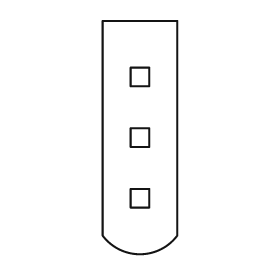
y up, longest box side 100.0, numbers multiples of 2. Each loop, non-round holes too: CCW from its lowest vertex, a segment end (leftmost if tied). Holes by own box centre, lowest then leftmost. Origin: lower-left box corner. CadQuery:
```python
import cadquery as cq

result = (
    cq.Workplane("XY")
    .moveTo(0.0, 8.0)
    .threePointArc((16.0, 0.0), (32.0, 8.0))
    .lineTo(32.0, 100.0)
    .lineTo(0.0, 100.0)
    .close()
    .moveTo(12.0, 20.0)
    .lineTo(20.0, 20.0)
    .lineTo(20.0, 28.0)
    .lineTo(12.0, 28.0)
    .close()
    .moveTo(12.0, 46.0)
    .lineTo(20.0, 46.0)
    .lineTo(20.0, 54.0)
    .lineTo(12.0, 54.0)
    .close()
    .moveTo(12.0, 72.0)
    .lineTo(20.0, 72.0)
    .lineTo(20.0, 80.0)
    .lineTo(12.0, 80.0)
    .close()
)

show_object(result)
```